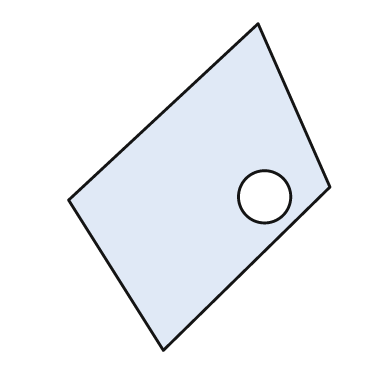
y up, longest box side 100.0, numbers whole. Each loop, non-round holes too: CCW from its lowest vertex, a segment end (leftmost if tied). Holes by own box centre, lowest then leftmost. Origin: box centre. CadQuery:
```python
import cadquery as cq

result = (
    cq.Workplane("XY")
    .moveTo(-11.0, -50.0)
    .lineTo(40.0, 0.0)
    .lineTo(18.0, 50.0)
    .lineTo(-40.0, -4.0)
    .close()
    .moveTo(20.0, -3.0)
    .circle(8.0)
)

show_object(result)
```